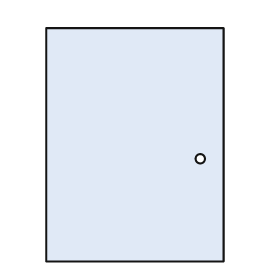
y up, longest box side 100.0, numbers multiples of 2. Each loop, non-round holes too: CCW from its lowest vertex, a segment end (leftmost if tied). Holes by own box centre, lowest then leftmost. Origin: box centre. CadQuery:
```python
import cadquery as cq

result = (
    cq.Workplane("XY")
    .moveTo(-38.0, -50.0)
    .lineTo(38.0, -50.0)
    .lineTo(38.0, 50.0)
    .lineTo(-38.0, 50.0)
    .close()
    .moveTo(28.0, -6.0)
    .circle(2.0)
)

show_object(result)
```